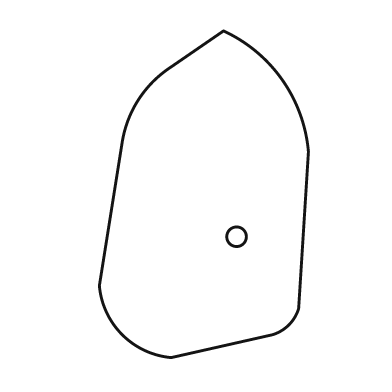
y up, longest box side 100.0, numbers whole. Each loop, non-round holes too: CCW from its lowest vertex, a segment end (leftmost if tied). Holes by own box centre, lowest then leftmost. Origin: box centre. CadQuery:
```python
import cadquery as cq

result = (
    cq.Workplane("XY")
    .moveTo(-10.0, -50.0)
    .lineTo(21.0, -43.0)
    .threePointArc((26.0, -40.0), (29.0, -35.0))
    .lineTo(32.0, 13.0)
    .threePointArc((24.0, 35.0), (6.0, 50.0))
    .lineTo(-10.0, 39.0)
    .threePointArc((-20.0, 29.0), (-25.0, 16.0))
    .lineTo(-32.0, -28.0)
    .threePointArc((-25.0, -43.0), (-10.0, -50.0))
    .close()
    .moveTo(10.0, -13.0)
    .circle(3.0)
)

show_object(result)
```